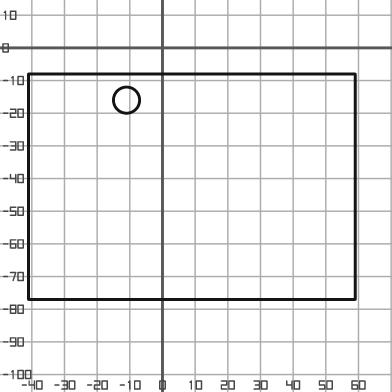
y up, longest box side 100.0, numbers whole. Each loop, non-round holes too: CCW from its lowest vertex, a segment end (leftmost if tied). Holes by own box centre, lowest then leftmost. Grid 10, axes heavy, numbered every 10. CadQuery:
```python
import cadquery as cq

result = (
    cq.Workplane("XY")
    .moveTo(-41.0, -77.0)
    .lineTo(59.0, -77.0)
    .lineTo(59.0, -8.0)
    .lineTo(-41.0, -8.0)
    .close()
    .moveTo(-11.0, -16.0)
    .circle(4.0)
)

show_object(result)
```